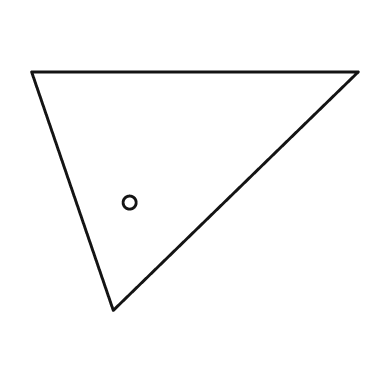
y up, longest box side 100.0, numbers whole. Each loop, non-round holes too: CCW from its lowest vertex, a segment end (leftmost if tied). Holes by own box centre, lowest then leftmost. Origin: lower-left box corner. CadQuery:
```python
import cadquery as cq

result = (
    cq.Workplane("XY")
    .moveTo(25.0, 0.0)
    .lineTo(100.0, 73.0)
    .lineTo(0.0, 73.0)
    .close()
    .moveTo(30.0, 33.0)
    .circle(2.0)
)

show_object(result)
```